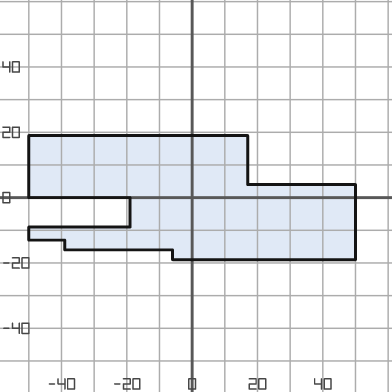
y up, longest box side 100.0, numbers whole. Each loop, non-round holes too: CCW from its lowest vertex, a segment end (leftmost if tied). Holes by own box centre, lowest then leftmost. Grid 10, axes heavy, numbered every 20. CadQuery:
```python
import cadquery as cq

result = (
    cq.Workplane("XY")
    .moveTo(-6.0, -19.0)
    .lineTo(50.0, -19.0)
    .lineTo(50.0, 4.0)
    .lineTo(17.0, 4.0)
    .lineTo(17.0, 19.0)
    .lineTo(-50.0, 19.0)
    .lineTo(-50.0, 0.0)
    .lineTo(-19.0, 0.0)
    .lineTo(-19.0, -9.0)
    .lineTo(-50.0, -9.0)
    .lineTo(-50.0, -13.0)
    .lineTo(-39.0, -13.0)
    .lineTo(-39.0, -16.0)
    .lineTo(-6.0, -16.0)
    .close()
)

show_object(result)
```